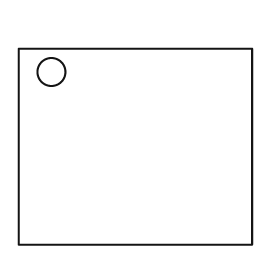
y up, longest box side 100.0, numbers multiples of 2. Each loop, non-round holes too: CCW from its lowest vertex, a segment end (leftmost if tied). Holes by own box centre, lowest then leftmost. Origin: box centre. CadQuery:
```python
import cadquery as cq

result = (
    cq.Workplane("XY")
    .moveTo(-50.0, -42.0)
    .lineTo(50.0, -42.0)
    .lineTo(50.0, 42.0)
    .lineTo(-50.0, 42.0)
    .close()
    .moveTo(-36.0, 32.0)
    .circle(6.0)
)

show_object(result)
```